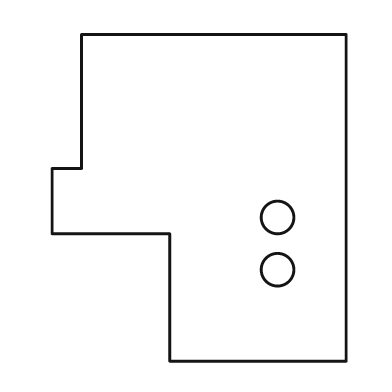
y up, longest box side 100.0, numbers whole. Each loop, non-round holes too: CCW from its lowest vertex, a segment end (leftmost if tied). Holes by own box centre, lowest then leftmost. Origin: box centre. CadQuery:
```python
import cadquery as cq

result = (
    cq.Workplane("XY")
    .moveTo(-9.0, -50.0)
    .lineTo(45.0, -50.0)
    .lineTo(45.0, 50.0)
    .lineTo(-36.0, 50.0)
    .lineTo(-36.0, 9.0)
    .lineTo(-45.0, 9.0)
    .lineTo(-45.0, -11.0)
    .lineTo(-9.0, -11.0)
    .close()
    .moveTo(24.0, -22.0)
    .circle(5.0)
    .moveTo(24.0, -6.0)
    .circle(5.0)
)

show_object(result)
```